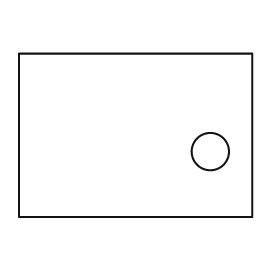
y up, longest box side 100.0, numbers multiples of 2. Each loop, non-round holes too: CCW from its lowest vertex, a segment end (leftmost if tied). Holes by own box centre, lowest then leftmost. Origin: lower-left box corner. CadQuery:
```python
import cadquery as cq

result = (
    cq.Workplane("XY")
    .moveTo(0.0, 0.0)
    .lineTo(100.0, 0.0)
    .lineTo(100.0, 70.0)
    .lineTo(0.0, 70.0)
    .close()
    .moveTo(82.0, 28.0)
    .circle(8.0)
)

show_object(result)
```